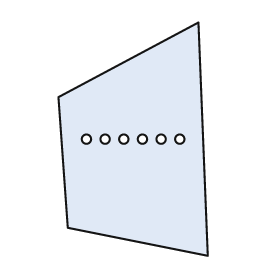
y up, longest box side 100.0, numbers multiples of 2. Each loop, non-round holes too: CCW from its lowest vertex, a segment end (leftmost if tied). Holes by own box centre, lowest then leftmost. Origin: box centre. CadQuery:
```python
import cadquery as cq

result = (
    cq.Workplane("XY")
    .moveTo(32.0, -50.0)
    .lineTo(28.0, 50.0)
    .lineTo(-32.0, 18.0)
    .lineTo(-28.0, -38.0)
    .close()
    .moveTo(-20.0, 0.0)
    .circle(2.0)
    .moveTo(-12.0, 0.0)
    .circle(2.0)
    .moveTo(-4.0, 0.0)
    .circle(2.0)
    .moveTo(4.0, 0.0)
    .circle(2.0)
    .moveTo(12.0, 0.0)
    .circle(2.0)
    .moveTo(20.0, 0.0)
    .circle(2.0)
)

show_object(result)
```